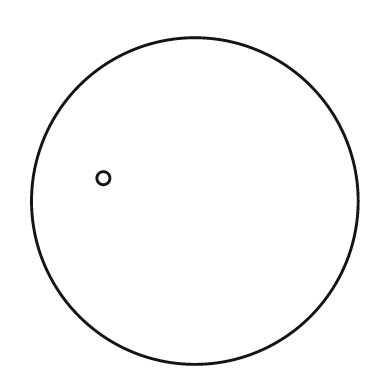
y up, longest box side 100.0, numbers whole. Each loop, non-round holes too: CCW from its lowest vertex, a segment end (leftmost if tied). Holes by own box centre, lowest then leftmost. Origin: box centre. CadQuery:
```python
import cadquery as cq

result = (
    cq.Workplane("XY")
    .moveTo(0.0, 0.0)
    .circle(50.0)
    .moveTo(-28.0, 7.0)
    .circle(2.0)
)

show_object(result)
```